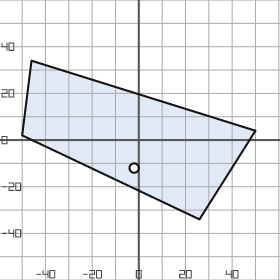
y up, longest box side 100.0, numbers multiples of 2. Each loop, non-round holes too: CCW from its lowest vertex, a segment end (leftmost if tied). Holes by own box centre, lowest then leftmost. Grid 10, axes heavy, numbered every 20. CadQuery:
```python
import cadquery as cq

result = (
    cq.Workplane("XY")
    .moveTo(26.0, -34.0)
    .lineTo(50.0, 4.0)
    .lineTo(-46.0, 34.0)
    .lineTo(-50.0, 2.0)
    .close()
    .moveTo(-2.0, -12.0)
    .circle(2.0)
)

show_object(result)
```